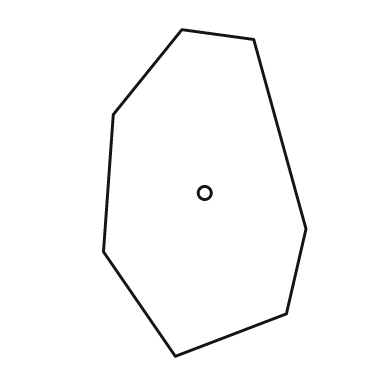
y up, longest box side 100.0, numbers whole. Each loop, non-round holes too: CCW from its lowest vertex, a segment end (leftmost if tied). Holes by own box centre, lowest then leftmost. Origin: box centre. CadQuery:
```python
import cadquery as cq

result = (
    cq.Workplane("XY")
    .moveTo(-9.0, -50.0)
    .lineTo(25.0, -37.0)
    .lineTo(31.0, -11.0)
    .lineTo(15.0, 47.0)
    .lineTo(-7.0, 50.0)
    .lineTo(-28.0, 24.0)
    .lineTo(-31.0, -18.0)
    .close()
    .moveTo(0.0, 0.0)
    .circle(2.0)
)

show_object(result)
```